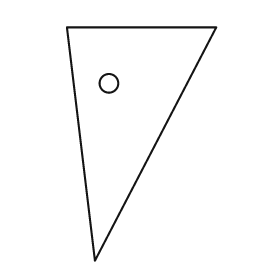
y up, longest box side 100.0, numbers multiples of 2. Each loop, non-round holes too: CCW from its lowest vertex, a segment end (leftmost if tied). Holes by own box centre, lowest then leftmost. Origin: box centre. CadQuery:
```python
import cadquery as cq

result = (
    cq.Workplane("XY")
    .moveTo(-20.0, -50.0)
    .lineTo(32.0, 50.0)
    .lineTo(-32.0, 50.0)
    .close()
    .moveTo(-14.0, 26.0)
    .circle(4.0)
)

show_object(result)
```